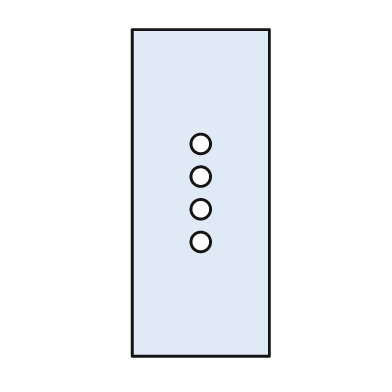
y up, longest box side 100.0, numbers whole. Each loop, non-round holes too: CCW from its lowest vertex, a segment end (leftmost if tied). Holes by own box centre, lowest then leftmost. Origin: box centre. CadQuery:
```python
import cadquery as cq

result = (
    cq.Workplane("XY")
    .moveTo(-21.0, -50.0)
    .lineTo(21.0, -50.0)
    .lineTo(21.0, 50.0)
    .lineTo(-21.0, 50.0)
    .close()
    .moveTo(0.0, -15.0)
    .circle(3.0)
    .moveTo(0.0, -5.0)
    .circle(3.0)
    .moveTo(0.0, 5.0)
    .circle(3.0)
    .moveTo(0.0, 15.0)
    .circle(3.0)
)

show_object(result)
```